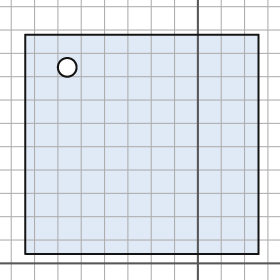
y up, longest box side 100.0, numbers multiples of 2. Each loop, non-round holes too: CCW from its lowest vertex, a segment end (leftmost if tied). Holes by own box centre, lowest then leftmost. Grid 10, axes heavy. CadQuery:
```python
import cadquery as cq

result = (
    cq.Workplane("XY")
    .moveTo(-74.0, 4.0)
    .lineTo(26.0, 4.0)
    .lineTo(26.0, 98.0)
    .lineTo(-74.0, 98.0)
    .close()
    .moveTo(-56.0, 84.0)
    .circle(4.0)
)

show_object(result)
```